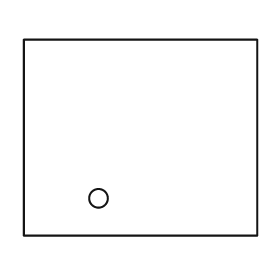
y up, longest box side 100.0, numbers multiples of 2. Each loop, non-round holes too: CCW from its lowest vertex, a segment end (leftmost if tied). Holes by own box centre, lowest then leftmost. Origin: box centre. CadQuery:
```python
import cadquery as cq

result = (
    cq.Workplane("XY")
    .moveTo(-50.0, -42.0)
    .lineTo(50.0, -42.0)
    .lineTo(50.0, 42.0)
    .lineTo(-50.0, 42.0)
    .close()
    .moveTo(-18.0, -26.0)
    .circle(4.0)
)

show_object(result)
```